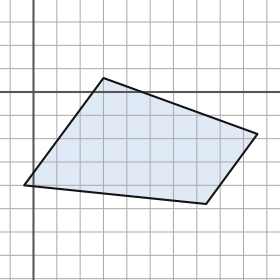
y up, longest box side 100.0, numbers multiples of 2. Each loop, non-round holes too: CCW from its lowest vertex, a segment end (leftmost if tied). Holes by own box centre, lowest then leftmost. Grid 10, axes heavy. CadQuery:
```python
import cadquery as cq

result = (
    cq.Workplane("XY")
    .moveTo(74.0, -48.0)
    .lineTo(96.0, -18.0)
    .lineTo(30.0, 6.0)
    .lineTo(-4.0, -40.0)
    .close()
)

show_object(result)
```